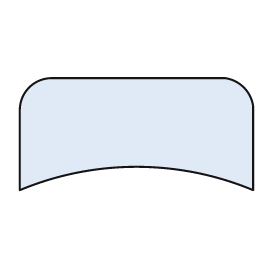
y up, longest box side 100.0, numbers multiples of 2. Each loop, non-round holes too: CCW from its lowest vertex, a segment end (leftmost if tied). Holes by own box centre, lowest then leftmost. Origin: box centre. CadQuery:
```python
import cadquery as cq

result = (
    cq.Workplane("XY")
    .moveTo(-50.0, -24.0)
    .threePointArc((0.0, -14.0), (50.0, -24.0))
    .lineTo(50.0, 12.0)
    .threePointArc((46.0, 20.0), (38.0, 24.0))
    .lineTo(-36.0, 24.0)
    .threePointArc((-46.0, 20.0), (-50.0, 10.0))
    .close()
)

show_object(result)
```